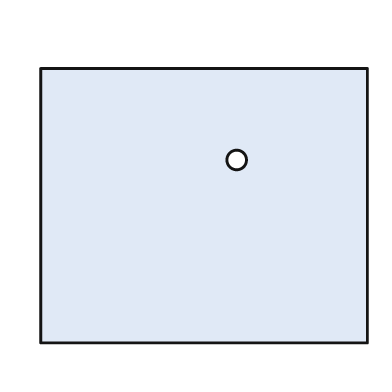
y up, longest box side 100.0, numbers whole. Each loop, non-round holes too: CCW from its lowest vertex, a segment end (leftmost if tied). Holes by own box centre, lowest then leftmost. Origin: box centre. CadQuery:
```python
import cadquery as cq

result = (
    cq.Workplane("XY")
    .moveTo(-50.0, -42.0)
    .lineTo(50.0, -42.0)
    .lineTo(50.0, 42.0)
    .lineTo(-50.0, 42.0)
    .close()
    .moveTo(10.0, 14.0)
    .circle(3.0)
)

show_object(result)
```